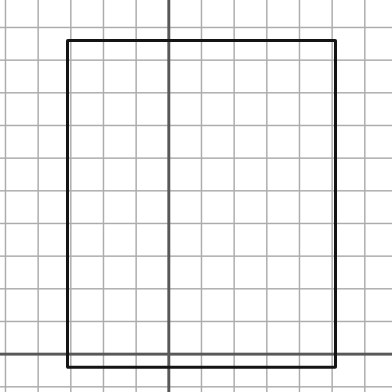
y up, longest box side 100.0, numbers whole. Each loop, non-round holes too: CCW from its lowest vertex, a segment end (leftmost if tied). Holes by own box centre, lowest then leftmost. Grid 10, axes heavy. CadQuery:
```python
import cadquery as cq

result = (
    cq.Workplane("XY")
    .moveTo(-31.0, -4.0)
    .lineTo(51.0, -4.0)
    .lineTo(51.0, 96.0)
    .lineTo(-31.0, 96.0)
    .close()
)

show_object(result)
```